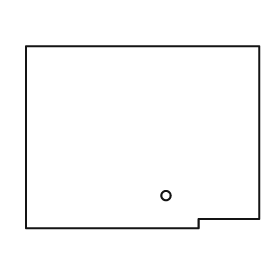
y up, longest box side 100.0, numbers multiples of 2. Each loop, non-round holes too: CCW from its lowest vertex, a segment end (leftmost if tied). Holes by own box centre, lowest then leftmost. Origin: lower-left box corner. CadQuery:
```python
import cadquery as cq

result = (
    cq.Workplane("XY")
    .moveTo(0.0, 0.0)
    .lineTo(74.0, 0.0)
    .lineTo(74.0, 4.0)
    .lineTo(100.0, 4.0)
    .lineTo(100.0, 78.0)
    .lineTo(0.0, 78.0)
    .close()
    .moveTo(60.0, 14.0)
    .circle(2.0)
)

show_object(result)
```